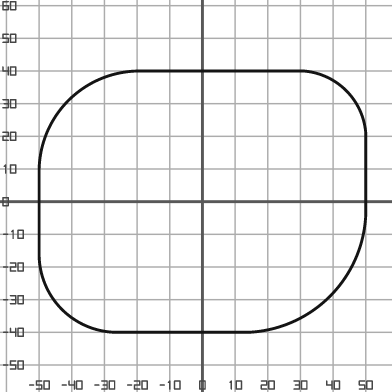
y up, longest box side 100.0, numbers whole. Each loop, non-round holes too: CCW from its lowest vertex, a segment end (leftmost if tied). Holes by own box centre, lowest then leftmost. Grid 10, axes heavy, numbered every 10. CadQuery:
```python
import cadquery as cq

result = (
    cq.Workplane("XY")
    .moveTo(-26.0, -40.0)
    .lineTo(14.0, -40.0)
    .threePointArc((39.0, -29.0), (50.0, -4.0))
    .lineTo(50.0, 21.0)
    .threePointArc((44.0, 34.0), (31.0, 40.0))
    .lineTo(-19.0, 40.0)
    .threePointArc((-41.0, 31.0), (-50.0, 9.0))
    .lineTo(-50.0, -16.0)
    .threePointArc((-43.0, -33.0), (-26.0, -40.0))
    .close()
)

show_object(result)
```